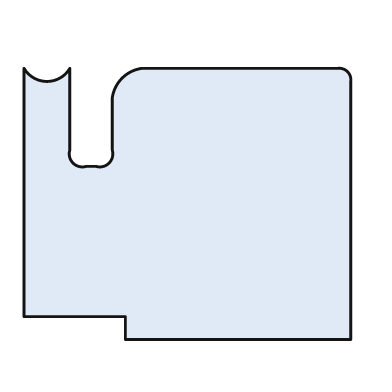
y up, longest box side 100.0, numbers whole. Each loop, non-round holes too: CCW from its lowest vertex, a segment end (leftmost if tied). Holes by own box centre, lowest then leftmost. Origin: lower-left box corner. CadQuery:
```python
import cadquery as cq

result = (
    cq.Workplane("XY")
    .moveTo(31.0, 0.0)
    .lineTo(100.0, 0.0)
    .lineTo(100.0, 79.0)
    .threePointArc((99.0, 82.0), (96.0, 83.0))
    .lineTo(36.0, 83.0)
    .threePointArc((30.0, 80.0), (27.0, 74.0))
    .lineTo(27.0, 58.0)
    .threePointArc((26.0, 54.0), (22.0, 53.0))
    .lineTo(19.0, 53.0)
    .threePointArc((15.0, 54.0), (14.0, 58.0))
    .lineTo(14.0, 83.0)
    .threePointArc((7.0, 79.0), (0.0, 83.0))
    .lineTo(0.0, 7.0)
    .lineTo(31.0, 7.0)
    .close()
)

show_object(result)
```